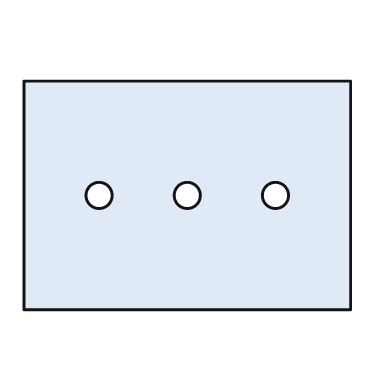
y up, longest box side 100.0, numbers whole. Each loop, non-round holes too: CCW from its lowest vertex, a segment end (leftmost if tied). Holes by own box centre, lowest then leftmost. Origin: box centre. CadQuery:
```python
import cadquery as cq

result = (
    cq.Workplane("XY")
    .moveTo(-50.0, -35.0)
    .lineTo(50.0, -35.0)
    .lineTo(50.0, 35.0)
    .lineTo(-50.0, 35.0)
    .close()
    .moveTo(-27.0, 0.0)
    .circle(4.0)
    .moveTo(0.0, 0.0)
    .circle(4.0)
    .moveTo(27.0, 0.0)
    .circle(4.0)
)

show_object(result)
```